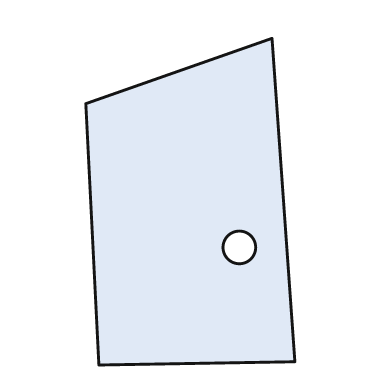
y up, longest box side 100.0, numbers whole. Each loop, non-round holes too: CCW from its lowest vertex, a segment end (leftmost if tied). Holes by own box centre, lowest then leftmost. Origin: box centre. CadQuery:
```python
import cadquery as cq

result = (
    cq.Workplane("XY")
    .moveTo(-28.0, -50.0)
    .lineTo(32.0, -49.0)
    .lineTo(25.0, 50.0)
    .lineTo(-32.0, 30.0)
    .close()
    .moveTo(15.0, -14.0)
    .circle(5.0)
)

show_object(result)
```